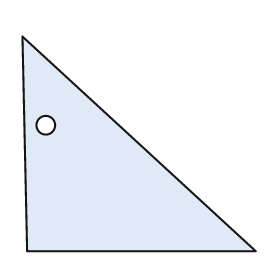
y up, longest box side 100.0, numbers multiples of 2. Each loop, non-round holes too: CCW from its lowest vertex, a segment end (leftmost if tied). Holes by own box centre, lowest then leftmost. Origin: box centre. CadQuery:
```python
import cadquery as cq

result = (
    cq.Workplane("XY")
    .moveTo(-48.0, -46.0)
    .lineTo(50.0, -46.0)
    .lineTo(-50.0, 46.0)
    .close()
    .moveTo(-40.0, 8.0)
    .circle(4.0)
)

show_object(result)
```